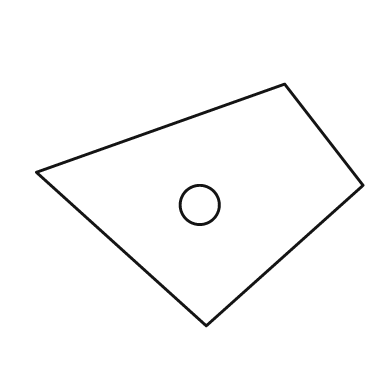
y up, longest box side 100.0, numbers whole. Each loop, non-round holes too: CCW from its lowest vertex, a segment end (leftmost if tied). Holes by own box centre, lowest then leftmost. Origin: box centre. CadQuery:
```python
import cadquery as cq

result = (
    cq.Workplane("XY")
    .moveTo(2.0, -37.0)
    .lineTo(50.0, 6.0)
    .lineTo(26.0, 37.0)
    .lineTo(-50.0, 10.0)
    .close()
    .moveTo(0.0, 0.0)
    .circle(6.0)
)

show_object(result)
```